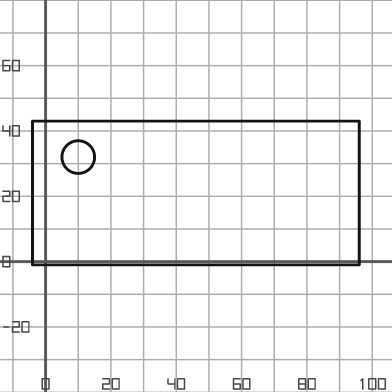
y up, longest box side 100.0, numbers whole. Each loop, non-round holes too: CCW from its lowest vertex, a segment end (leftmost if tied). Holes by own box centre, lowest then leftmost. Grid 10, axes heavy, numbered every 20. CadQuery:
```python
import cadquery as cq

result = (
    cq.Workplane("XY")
    .moveTo(-4.0, -1.0)
    .lineTo(96.0, -1.0)
    .lineTo(96.0, 43.0)
    .lineTo(-4.0, 43.0)
    .close()
    .moveTo(10.0, 32.0)
    .circle(5.0)
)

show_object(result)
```